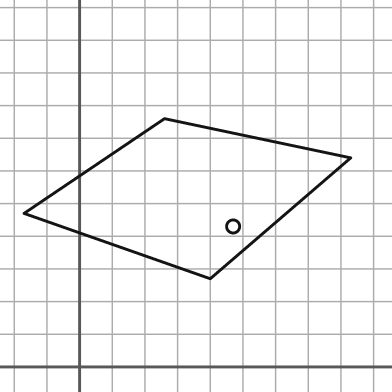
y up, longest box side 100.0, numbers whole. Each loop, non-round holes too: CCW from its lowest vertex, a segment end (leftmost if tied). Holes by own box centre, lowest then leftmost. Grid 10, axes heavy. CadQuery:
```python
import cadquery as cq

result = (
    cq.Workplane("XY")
    .moveTo(40.0, 27.0)
    .lineTo(83.0, 64.0)
    .lineTo(26.0, 76.0)
    .lineTo(-17.0, 47.0)
    .close()
    .moveTo(47.0, 43.0)
    .circle(2.0)
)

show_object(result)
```